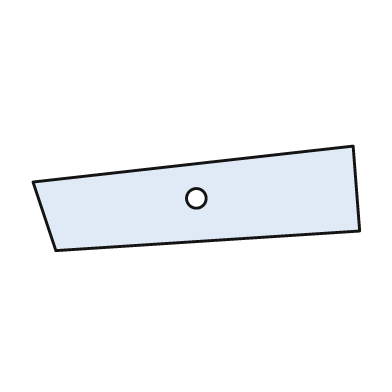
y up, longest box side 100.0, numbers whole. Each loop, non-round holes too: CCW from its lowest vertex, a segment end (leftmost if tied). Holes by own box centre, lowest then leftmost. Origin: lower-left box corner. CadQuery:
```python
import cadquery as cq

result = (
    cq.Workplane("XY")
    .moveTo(7.0, 0.0)
    .lineTo(100.0, 6.0)
    .lineTo(98.0, 32.0)
    .lineTo(0.0, 21.0)
    .close()
    .moveTo(50.0, 16.0)
    .circle(3.0)
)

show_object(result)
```